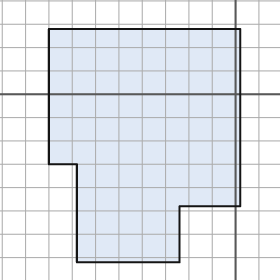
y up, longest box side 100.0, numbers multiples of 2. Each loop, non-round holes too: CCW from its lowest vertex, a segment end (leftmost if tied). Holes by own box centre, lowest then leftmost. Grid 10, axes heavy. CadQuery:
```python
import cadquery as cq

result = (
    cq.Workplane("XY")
    .moveTo(-68.0, -72.0)
    .lineTo(-24.0, -72.0)
    .lineTo(-24.0, -48.0)
    .lineTo(2.0, -48.0)
    .lineTo(2.0, 28.0)
    .lineTo(-80.0, 28.0)
    .lineTo(-80.0, -30.0)
    .lineTo(-68.0, -30.0)
    .close()
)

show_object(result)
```